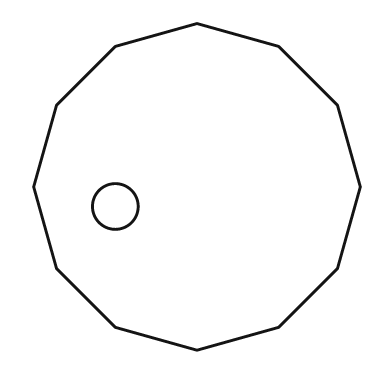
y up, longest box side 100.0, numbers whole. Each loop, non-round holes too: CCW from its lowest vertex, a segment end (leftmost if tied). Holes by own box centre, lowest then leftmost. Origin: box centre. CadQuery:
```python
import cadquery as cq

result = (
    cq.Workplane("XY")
    .moveTo(0.0, -50.0)
    .lineTo(25.0, -43.0)
    .lineTo(43.0, -25.0)
    .lineTo(50.0, 0.0)
    .lineTo(43.0, 25.0)
    .lineTo(25.0, 43.0)
    .lineTo(0.0, 50.0)
    .lineTo(-25.0, 43.0)
    .lineTo(-43.0, 25.0)
    .lineTo(-50.0, 0.0)
    .lineTo(-43.0, -25.0)
    .lineTo(-25.0, -43.0)
    .close()
    .moveTo(-25.0, -6.0)
    .circle(7.0)
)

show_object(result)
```